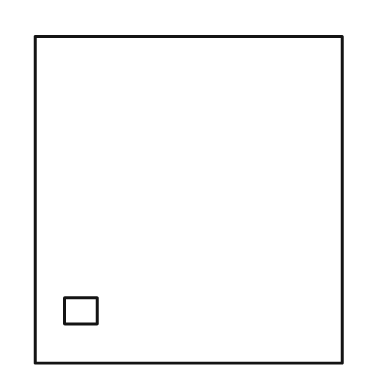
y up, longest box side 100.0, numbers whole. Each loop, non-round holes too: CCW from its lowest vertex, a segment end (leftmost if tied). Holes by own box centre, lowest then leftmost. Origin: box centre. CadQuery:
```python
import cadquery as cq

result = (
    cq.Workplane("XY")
    .moveTo(-47.0, -50.0)
    .lineTo(47.0, -50.0)
    .lineTo(47.0, 50.0)
    .lineTo(-47.0, 50.0)
    .close()
    .moveTo(-38.0, -38.0)
    .lineTo(-28.0, -38.0)
    .lineTo(-28.0, -30.0)
    .lineTo(-38.0, -30.0)
    .close()
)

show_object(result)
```